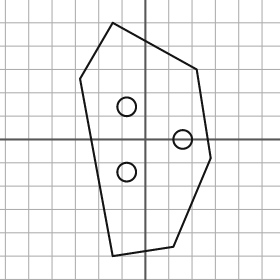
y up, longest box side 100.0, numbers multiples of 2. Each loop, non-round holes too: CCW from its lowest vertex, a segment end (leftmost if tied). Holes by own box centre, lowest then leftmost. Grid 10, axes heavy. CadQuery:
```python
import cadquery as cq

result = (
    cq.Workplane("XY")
    .moveTo(-14.0, -50.0)
    .lineTo(12.0, -46.0)
    .lineTo(28.0, -8.0)
    .lineTo(22.0, 30.0)
    .lineTo(-14.0, 50.0)
    .lineTo(-28.0, 26.0)
    .close()
    .moveTo(-8.0, -14.0)
    .circle(4.0)
    .moveTo(16.0, 0.0)
    .circle(4.0)
    .moveTo(-8.0, 14.0)
    .circle(4.0)
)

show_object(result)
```